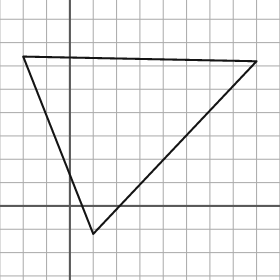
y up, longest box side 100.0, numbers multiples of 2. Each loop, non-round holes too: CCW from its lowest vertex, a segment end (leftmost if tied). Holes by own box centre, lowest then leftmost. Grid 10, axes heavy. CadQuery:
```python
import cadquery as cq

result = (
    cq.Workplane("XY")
    .moveTo(10.0, -12.0)
    .lineTo(80.0, 62.0)
    .lineTo(-20.0, 64.0)
    .close()
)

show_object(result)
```